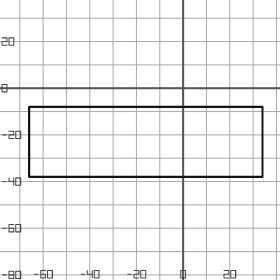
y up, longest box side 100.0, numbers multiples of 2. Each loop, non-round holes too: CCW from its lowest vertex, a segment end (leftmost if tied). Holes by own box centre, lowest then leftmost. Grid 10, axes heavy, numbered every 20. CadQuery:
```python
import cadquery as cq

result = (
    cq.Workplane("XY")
    .moveTo(-66.0, -38.0)
    .lineTo(34.0, -38.0)
    .lineTo(34.0, -8.0)
    .lineTo(-66.0, -8.0)
    .close()
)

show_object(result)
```